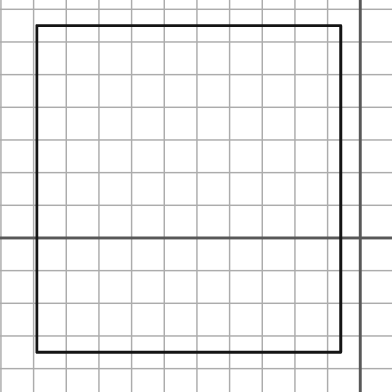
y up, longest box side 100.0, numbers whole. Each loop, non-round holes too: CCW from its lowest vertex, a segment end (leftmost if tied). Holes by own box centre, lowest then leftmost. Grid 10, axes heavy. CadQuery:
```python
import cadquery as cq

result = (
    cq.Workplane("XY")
    .moveTo(-99.0, -35.0)
    .lineTo(-6.0, -35.0)
    .lineTo(-6.0, 65.0)
    .lineTo(-99.0, 65.0)
    .close()
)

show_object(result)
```